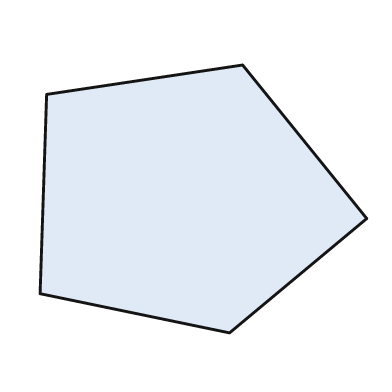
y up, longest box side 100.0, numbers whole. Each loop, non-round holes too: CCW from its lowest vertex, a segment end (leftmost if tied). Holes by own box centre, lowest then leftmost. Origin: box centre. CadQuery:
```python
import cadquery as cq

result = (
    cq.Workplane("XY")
    .moveTo(8.0, -41.0)
    .lineTo(50.0, -6.0)
    .lineTo(12.0, 41.0)
    .lineTo(-48.0, 32.0)
    .lineTo(-50.0, -29.0)
    .close()
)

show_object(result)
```